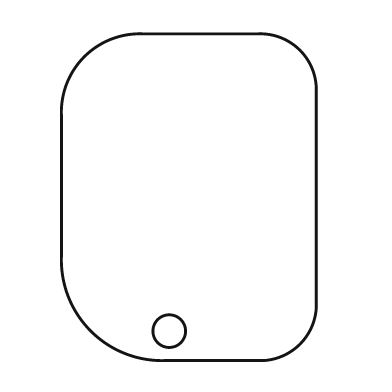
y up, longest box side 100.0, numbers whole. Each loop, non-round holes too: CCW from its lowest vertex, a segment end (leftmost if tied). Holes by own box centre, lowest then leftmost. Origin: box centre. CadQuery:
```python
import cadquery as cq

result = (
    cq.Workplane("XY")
    .moveTo(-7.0, -50.0)
    .lineTo(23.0, -50.0)
    .threePointArc((34.0, -45.0), (39.0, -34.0))
    .lineTo(39.0, 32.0)
    .threePointArc((34.0, 45.0), (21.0, 50.0))
    .lineTo(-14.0, 50.0)
    .threePointArc((-32.0, 43.0), (-39.0, 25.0))
    .lineTo(-39.0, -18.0)
    .threePointArc((-30.0, -41.0), (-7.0, -50.0))
    .close()
    .moveTo(-6.0, -41.0)
    .circle(5.0)
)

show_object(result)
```